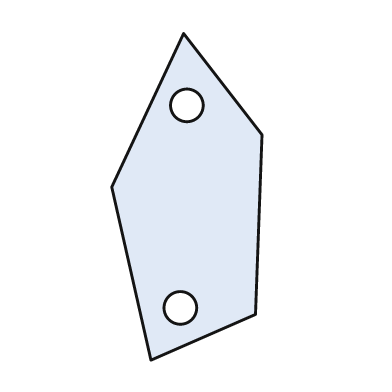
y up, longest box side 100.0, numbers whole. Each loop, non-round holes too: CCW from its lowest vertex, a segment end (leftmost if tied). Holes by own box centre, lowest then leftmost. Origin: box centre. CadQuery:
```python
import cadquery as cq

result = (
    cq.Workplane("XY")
    .moveTo(-11.0, -50.0)
    .lineTo(21.0, -36.0)
    .lineTo(23.0, 19.0)
    .lineTo(-1.0, 50.0)
    .lineTo(-23.0, 3.0)
    .close()
    .moveTo(-2.0, -34.0)
    .circle(5.0)
    .moveTo(0.0, 28.0)
    .circle(5.0)
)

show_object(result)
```